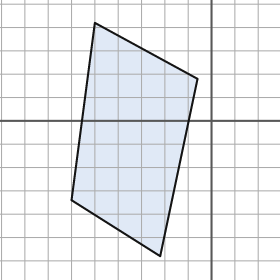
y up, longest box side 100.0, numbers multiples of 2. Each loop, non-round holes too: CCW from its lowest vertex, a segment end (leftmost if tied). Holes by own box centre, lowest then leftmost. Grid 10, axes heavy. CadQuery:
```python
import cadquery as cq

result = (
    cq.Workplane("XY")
    .moveTo(-22.0, -58.0)
    .lineTo(-6.0, 18.0)
    .lineTo(-50.0, 42.0)
    .lineTo(-60.0, -34.0)
    .close()
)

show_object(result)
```